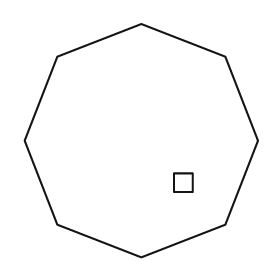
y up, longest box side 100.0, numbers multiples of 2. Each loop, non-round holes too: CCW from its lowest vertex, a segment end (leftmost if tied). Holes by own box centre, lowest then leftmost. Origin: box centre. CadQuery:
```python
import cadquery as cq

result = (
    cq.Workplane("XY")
    .moveTo(0.0, -50.0)
    .lineTo(36.0, -36.0)
    .lineTo(50.0, 0.0)
    .lineTo(36.0, 36.0)
    .lineTo(0.0, 50.0)
    .lineTo(-36.0, 36.0)
    .lineTo(-50.0, 0.0)
    .lineTo(-36.0, -36.0)
    .close()
    .moveTo(14.0, -22.0)
    .lineTo(22.0, -22.0)
    .lineTo(22.0, -14.0)
    .lineTo(14.0, -14.0)
    .close()
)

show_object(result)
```